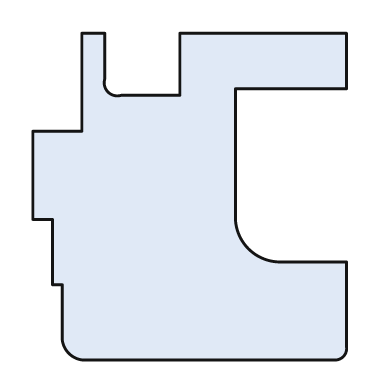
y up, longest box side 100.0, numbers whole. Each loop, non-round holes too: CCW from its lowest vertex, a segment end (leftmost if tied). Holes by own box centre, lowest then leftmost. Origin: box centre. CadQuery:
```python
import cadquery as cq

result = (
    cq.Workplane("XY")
    .moveTo(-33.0, -50.0)
    .lineTo(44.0, -50.0)
    .threePointArc((47.0, -49.0), (48.0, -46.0))
    .lineTo(48.0, -20.0)
    .lineTo(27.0, -20.0)
    .threePointArc((18.0, -16.0), (14.0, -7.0))
    .lineTo(14.0, 33.0)
    .lineTo(48.0, 33.0)
    .lineTo(48.0, 50.0)
    .lineTo(-3.0, 50.0)
    .lineTo(-3.0, 31.0)
    .lineTo(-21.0, 31.0)
    .threePointArc((-25.0, 32.0), (-26.0, 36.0))
    .lineTo(-26.0, 50.0)
    .lineTo(-33.0, 50.0)
    .lineTo(-33.0, 20.0)
    .lineTo(-48.0, 20.0)
    .lineTo(-48.0, -7.0)
    .lineTo(-42.0, -7.0)
    .lineTo(-42.0, -27.0)
    .lineTo(-39.0, -27.0)
    .lineTo(-39.0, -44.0)
    .threePointArc((-37.0, -48.0), (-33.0, -50.0))
    .close()
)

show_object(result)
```